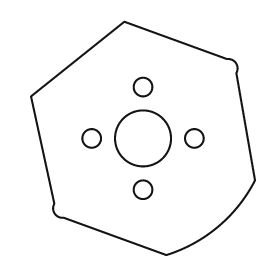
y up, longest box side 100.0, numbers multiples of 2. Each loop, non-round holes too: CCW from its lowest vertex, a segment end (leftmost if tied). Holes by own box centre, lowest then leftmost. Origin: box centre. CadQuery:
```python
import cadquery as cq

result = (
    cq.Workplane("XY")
    .moveTo(10.0, -50.0)
    .threePointArc((32.0, -38.0), (48.0, -18.0))
    .lineTo(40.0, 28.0)
    .threePointArc((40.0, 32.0), (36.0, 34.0))
    .lineTo(-8.0, 50.0)
    .lineTo(-48.0, 18.0)
    .lineTo(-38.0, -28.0)
    .threePointArc((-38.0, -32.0), (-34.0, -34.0))
    .close()
    .moveTo(0.0, -22.0)
    .circle(4.0)
    .moveTo(-22.0, 0.0)
    .circle(4.0)
    .moveTo(0.0, 0.0)
    .circle(12.0)
    .moveTo(22.0, 0.0)
    .circle(4.0)
    .moveTo(0.0, 22.0)
    .circle(4.0)
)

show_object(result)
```